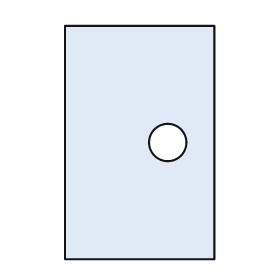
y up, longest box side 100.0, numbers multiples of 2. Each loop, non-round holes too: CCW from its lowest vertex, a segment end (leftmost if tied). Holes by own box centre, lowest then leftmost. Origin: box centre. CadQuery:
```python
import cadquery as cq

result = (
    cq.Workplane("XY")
    .moveTo(-32.0, -50.0)
    .lineTo(32.0, -50.0)
    .lineTo(32.0, 50.0)
    .lineTo(-32.0, 50.0)
    .close()
    .moveTo(12.0, 0.0)
    .circle(8.0)
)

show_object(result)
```